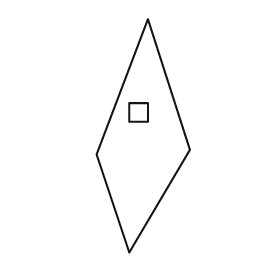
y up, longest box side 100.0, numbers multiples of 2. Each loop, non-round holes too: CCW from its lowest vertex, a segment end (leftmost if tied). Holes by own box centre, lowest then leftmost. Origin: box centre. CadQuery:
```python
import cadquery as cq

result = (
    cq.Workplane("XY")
    .moveTo(-6.0, -50.0)
    .lineTo(20.0, -6.0)
    .lineTo(2.0, 50.0)
    .lineTo(-20.0, -8.0)
    .close()
    .moveTo(-6.0, 6.0)
    .lineTo(2.0, 6.0)
    .lineTo(2.0, 14.0)
    .lineTo(-6.0, 14.0)
    .close()
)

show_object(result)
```